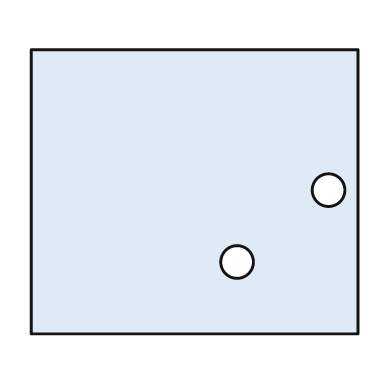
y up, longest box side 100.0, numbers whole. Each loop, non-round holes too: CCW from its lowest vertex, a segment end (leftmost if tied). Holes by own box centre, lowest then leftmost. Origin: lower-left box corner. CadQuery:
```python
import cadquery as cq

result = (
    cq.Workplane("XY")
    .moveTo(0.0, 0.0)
    .lineTo(100.0, 0.0)
    .lineTo(100.0, 87.0)
    .lineTo(0.0, 87.0)
    .close()
    .moveTo(63.0, 22.0)
    .circle(5.0)
    .moveTo(91.0, 44.0)
    .circle(5.0)
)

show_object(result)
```